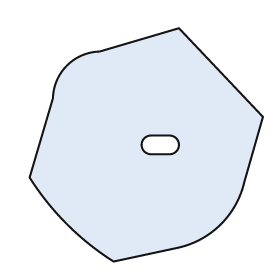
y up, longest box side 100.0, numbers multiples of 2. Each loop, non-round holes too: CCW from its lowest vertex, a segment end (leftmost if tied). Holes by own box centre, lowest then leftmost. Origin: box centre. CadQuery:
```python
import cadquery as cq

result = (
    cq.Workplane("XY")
    .moveTo(-14.0, -50.0)
    .lineTo(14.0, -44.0)
    .threePointArc((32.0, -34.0), (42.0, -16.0))
    .lineTo(50.0, 12.0)
    .lineTo(14.0, 50.0)
    .lineTo(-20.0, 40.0)
    .threePointArc((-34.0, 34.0), (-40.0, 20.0))
    .lineTo(-50.0, -14.0)
    .threePointArc((-34.0, -34.0), (-14.0, -50.0))
    .close()
    .moveTo(2.0, -4.0)
    .lineTo(10.0, -4.0)
    .threePointArc((14.0, 0.0), (10.0, 4.0))
    .lineTo(2.0, 4.0)
    .threePointArc((-2.0, 0.0), (2.0, -4.0))
    .close()
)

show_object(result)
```